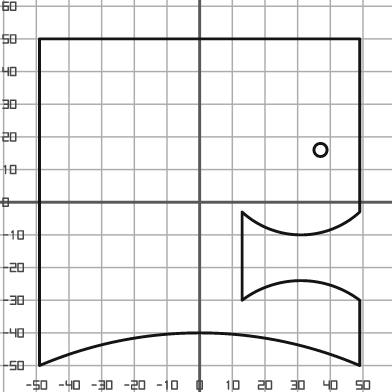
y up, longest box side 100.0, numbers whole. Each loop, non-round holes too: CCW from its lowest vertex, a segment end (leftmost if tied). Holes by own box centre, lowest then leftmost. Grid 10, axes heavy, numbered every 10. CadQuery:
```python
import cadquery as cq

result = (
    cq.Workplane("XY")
    .moveTo(-49.0, -50.0)
    .threePointArc((0.0, -40.0), (49.0, -50.0))
    .lineTo(49.0, -30.0)
    .threePointArc((31.0, -24.0), (13.0, -30.0))
    .lineTo(13.0, -3.0)
    .threePointArc((31.0, -10.0), (49.0, -3.0))
    .lineTo(49.0, 50.0)
    .lineTo(-49.0, 50.0)
    .close()
    .moveTo(37.0, 16.0)
    .circle(2.0)
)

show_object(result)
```